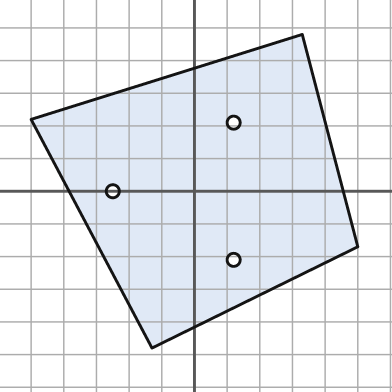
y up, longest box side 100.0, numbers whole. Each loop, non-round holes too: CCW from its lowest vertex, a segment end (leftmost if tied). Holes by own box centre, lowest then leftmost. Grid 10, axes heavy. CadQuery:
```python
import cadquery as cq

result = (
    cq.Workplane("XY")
    .moveTo(-13.0, -48.0)
    .lineTo(50.0, -17.0)
    .lineTo(33.0, 48.0)
    .lineTo(-50.0, 22.0)
    .close()
    .moveTo(12.0, -21.0)
    .circle(2.0)
    .moveTo(-25.0, 0.0)
    .circle(2.0)
    .moveTo(12.0, 21.0)
    .circle(2.0)
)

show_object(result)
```